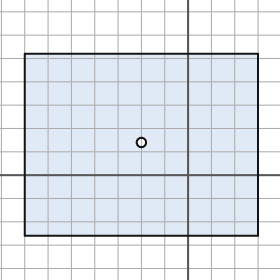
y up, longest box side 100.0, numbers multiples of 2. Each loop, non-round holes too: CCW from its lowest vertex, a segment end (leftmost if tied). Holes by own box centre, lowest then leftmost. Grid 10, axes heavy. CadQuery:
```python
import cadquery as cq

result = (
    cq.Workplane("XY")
    .moveTo(-70.0, -26.0)
    .lineTo(30.0, -26.0)
    .lineTo(30.0, 52.0)
    .lineTo(-70.0, 52.0)
    .close()
    .moveTo(-20.0, 14.0)
    .circle(2.0)
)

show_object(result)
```